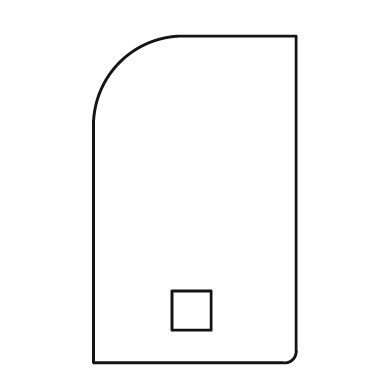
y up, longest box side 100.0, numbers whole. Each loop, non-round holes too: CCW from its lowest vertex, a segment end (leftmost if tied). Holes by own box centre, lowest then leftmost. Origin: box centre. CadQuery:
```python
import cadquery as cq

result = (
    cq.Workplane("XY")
    .moveTo(-31.0, -50.0)
    .lineTo(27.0, -50.0)
    .threePointArc((30.0, -49.0), (31.0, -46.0))
    .lineTo(31.0, 50.0)
    .lineTo(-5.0, 50.0)
    .threePointArc((-23.0, 42.0), (-31.0, 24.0))
    .close()
    .moveTo(-7.0, -40.0)
    .lineTo(5.0, -40.0)
    .lineTo(5.0, -28.0)
    .lineTo(-7.0, -28.0)
    .close()
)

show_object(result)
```